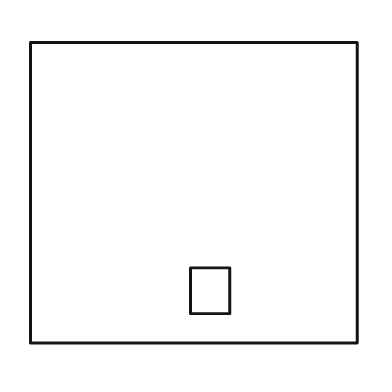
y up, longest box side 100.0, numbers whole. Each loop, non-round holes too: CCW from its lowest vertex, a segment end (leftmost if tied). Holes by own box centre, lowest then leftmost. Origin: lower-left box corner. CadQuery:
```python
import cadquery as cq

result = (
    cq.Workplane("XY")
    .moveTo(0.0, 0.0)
    .lineTo(100.0, 0.0)
    .lineTo(100.0, 92.0)
    .lineTo(0.0, 92.0)
    .close()
    .moveTo(49.0, 9.0)
    .lineTo(61.0, 9.0)
    .lineTo(61.0, 23.0)
    .lineTo(49.0, 23.0)
    .close()
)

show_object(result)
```